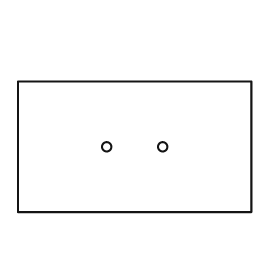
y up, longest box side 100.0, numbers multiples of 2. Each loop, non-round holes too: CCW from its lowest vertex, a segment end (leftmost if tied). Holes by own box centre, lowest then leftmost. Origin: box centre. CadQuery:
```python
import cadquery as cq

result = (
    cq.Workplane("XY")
    .moveTo(-50.0, -28.0)
    .lineTo(50.0, -28.0)
    .lineTo(50.0, 28.0)
    .lineTo(-50.0, 28.0)
    .close()
    .moveTo(-12.0, 0.0)
    .circle(2.0)
    .moveTo(12.0, 0.0)
    .circle(2.0)
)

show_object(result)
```